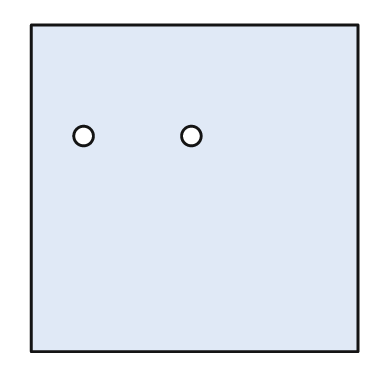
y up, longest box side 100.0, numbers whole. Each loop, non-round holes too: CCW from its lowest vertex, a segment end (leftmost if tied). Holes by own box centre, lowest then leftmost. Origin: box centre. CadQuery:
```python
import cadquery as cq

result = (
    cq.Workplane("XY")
    .moveTo(-50.0, -50.0)
    .lineTo(50.0, -50.0)
    .lineTo(50.0, 50.0)
    .lineTo(-50.0, 50.0)
    .close()
    .moveTo(-34.0, 16.0)
    .circle(3.0)
    .moveTo(-1.0, 16.0)
    .circle(3.0)
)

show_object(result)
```